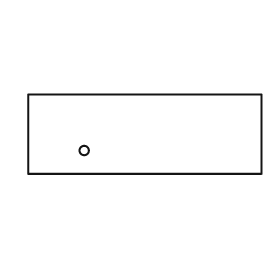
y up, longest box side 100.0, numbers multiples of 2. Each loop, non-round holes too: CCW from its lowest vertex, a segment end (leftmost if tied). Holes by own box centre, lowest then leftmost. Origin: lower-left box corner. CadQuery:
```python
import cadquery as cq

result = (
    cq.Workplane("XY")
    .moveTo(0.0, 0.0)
    .lineTo(100.0, 0.0)
    .lineTo(100.0, 34.0)
    .lineTo(0.0, 34.0)
    .close()
    .moveTo(24.0, 10.0)
    .circle(2.0)
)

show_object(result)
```